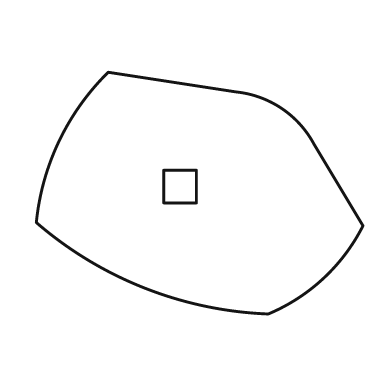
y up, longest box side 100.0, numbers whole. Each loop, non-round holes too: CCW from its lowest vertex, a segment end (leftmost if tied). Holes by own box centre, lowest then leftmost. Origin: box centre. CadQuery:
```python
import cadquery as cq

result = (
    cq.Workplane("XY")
    .moveTo(21.0, -37.0)
    .threePointArc((38.0, -26.0), (50.0, -10.0))
    .lineTo(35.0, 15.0)
    .threePointArc((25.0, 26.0), (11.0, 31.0))
    .lineTo(-28.0, 37.0)
    .threePointArc((-43.0, 16.0), (-50.0, -9.0))
    .threePointArc((-17.0, -29.0), (21.0, -37.0))
    .close()
    .moveTo(-11.0, -3.0)
    .lineTo(-1.0, -3.0)
    .lineTo(-1.0, 7.0)
    .lineTo(-11.0, 7.0)
    .close()
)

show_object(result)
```